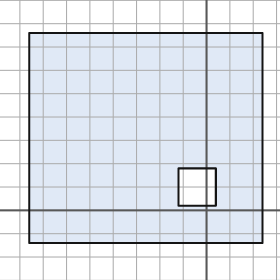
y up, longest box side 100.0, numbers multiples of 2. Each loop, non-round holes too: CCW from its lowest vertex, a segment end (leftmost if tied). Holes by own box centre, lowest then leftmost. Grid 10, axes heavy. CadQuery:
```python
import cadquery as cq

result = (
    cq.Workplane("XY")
    .moveTo(-76.0, -14.0)
    .lineTo(24.0, -14.0)
    .lineTo(24.0, 76.0)
    .lineTo(-76.0, 76.0)
    .close()
    .moveTo(-12.0, 2.0)
    .lineTo(4.0, 2.0)
    .lineTo(4.0, 18.0)
    .lineTo(-12.0, 18.0)
    .close()
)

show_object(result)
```